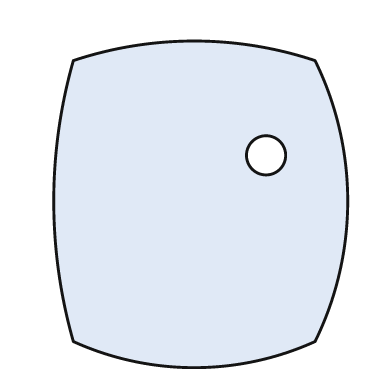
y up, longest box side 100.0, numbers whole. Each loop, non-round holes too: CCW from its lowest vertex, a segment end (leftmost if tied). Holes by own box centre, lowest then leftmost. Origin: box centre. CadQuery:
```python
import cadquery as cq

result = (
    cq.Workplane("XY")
    .moveTo(-39.0, -42.0)
    .threePointArc((-2.0, -50.0), (35.0, -42.0))
    .threePointArc((45.0, 1.0), (35.0, 44.0))
    .threePointArc((-2.0, 50.0), (-39.0, 44.0))
    .threePointArc((-45.0, 1.0), (-39.0, -42.0))
    .close()
    .moveTo(20.0, 15.0)
    .circle(6.0)
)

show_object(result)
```